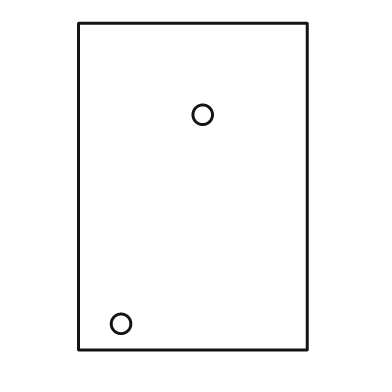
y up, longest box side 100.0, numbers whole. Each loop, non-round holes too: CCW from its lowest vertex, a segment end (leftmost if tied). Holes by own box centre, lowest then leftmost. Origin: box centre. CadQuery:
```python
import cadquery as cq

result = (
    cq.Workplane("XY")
    .moveTo(-35.0, -50.0)
    .lineTo(35.0, -50.0)
    .lineTo(35.0, 50.0)
    .lineTo(-35.0, 50.0)
    .close()
    .moveTo(-22.0, -42.0)
    .circle(3.0)
    .moveTo(3.0, 22.0)
    .circle(3.0)
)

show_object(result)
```